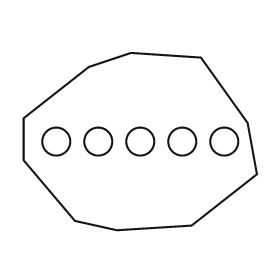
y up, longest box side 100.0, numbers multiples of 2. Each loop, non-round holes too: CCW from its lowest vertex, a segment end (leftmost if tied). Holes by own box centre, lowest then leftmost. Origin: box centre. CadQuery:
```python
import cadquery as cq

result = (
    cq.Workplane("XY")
    .moveTo(-10.0, -38.0)
    .lineTo(22.0, -36.0)
    .lineTo(50.0, -14.0)
    .lineTo(46.0, 8.0)
    .lineTo(26.0, 36.0)
    .lineTo(-4.0, 38.0)
    .lineTo(-22.0, 32.0)
    .lineTo(-50.0, 10.0)
    .lineTo(-50.0, -8.0)
    .lineTo(-28.0, -34.0)
    .close()
    .moveTo(-36.0, 0.0)
    .circle(6.0)
    .moveTo(-18.0, 0.0)
    .circle(6.0)
    .moveTo(0.0, 0.0)
    .circle(6.0)
    .moveTo(18.0, 0.0)
    .circle(6.0)
    .moveTo(36.0, 0.0)
    .circle(6.0)
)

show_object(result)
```